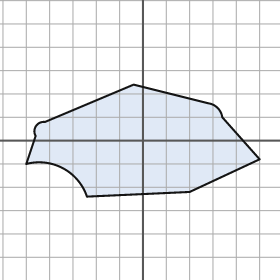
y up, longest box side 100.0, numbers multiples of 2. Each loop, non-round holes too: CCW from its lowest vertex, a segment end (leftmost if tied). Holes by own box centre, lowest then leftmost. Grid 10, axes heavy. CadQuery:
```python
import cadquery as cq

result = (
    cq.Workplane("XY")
    .moveTo(-24.0, -24.0)
    .lineTo(20.0, -22.0)
    .lineTo(50.0, -8.0)
    .lineTo(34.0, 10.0)
    .threePointArc((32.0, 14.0), (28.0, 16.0))
    .lineTo(-4.0, 24.0)
    .lineTo(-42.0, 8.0)
    .threePointArc((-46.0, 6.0), (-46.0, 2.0))
    .lineTo(-50.0, -10.0)
    .threePointArc((-34.0, -12.0), (-24.0, -24.0))
    .close()
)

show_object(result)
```